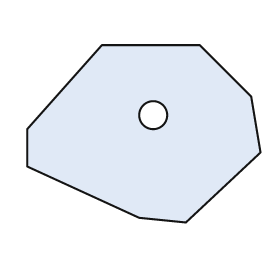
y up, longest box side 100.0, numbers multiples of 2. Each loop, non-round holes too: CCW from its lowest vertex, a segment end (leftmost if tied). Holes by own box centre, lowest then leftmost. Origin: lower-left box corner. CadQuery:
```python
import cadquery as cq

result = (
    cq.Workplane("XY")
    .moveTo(68.0, 0.0)
    .lineTo(100.0, 30.0)
    .lineTo(96.0, 54.0)
    .lineTo(74.0, 76.0)
    .lineTo(32.0, 76.0)
    .lineTo(0.0, 40.0)
    .lineTo(0.0, 24.0)
    .lineTo(48.0, 2.0)
    .close()
    .moveTo(54.0, 46.0)
    .circle(6.0)
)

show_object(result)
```